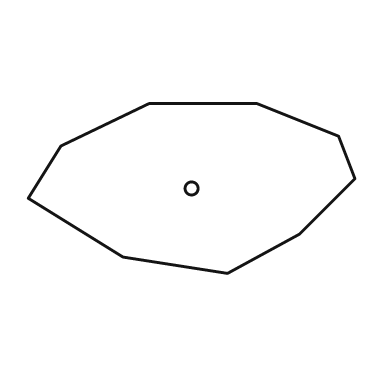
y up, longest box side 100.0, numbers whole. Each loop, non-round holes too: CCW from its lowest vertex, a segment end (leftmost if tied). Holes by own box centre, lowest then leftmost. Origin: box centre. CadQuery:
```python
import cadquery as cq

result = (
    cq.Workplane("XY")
    .moveTo(11.0, -26.0)
    .lineTo(33.0, -14.0)
    .lineTo(50.0, 3.0)
    .lineTo(45.0, 16.0)
    .lineTo(20.0, 26.0)
    .lineTo(-13.0, 26.0)
    .lineTo(-40.0, 13.0)
    .lineTo(-50.0, -3.0)
    .lineTo(-21.0, -21.0)
    .close()
    .moveTo(0.0, 0.0)
    .circle(2.0)
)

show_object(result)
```